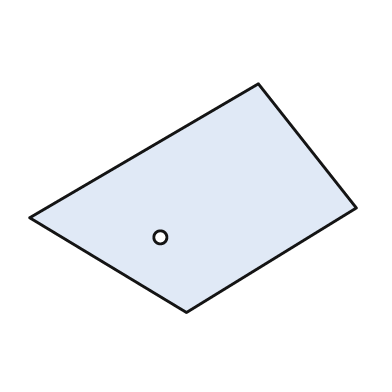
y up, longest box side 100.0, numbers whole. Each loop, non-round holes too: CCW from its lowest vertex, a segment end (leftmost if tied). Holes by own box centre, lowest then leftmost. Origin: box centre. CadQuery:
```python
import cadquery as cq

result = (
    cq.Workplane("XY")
    .moveTo(-2.0, -35.0)
    .lineTo(50.0, -3.0)
    .lineTo(20.0, 35.0)
    .lineTo(-50.0, -6.0)
    .close()
    .moveTo(-10.0, -12.0)
    .circle(2.0)
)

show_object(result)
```